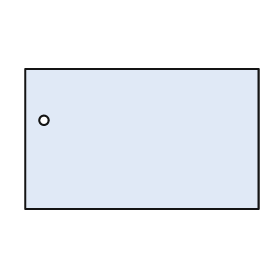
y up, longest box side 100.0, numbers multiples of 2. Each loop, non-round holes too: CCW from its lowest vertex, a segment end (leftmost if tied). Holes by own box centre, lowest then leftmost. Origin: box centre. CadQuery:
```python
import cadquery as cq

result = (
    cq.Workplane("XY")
    .moveTo(-50.0, -30.0)
    .lineTo(50.0, -30.0)
    .lineTo(50.0, 30.0)
    .lineTo(-50.0, 30.0)
    .close()
    .moveTo(-42.0, 8.0)
    .circle(2.0)
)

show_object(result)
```